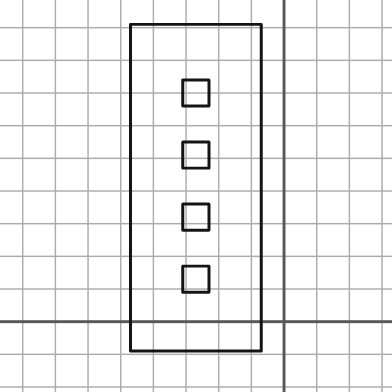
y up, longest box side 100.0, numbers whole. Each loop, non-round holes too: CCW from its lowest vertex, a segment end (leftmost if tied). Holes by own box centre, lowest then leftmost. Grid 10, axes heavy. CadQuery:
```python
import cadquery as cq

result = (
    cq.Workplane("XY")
    .moveTo(-47.0, -9.0)
    .lineTo(-7.0, -9.0)
    .lineTo(-7.0, 91.0)
    .lineTo(-47.0, 91.0)
    .close()
    .moveTo(-31.0, 9.0)
    .lineTo(-23.0, 9.0)
    .lineTo(-23.0, 17.0)
    .lineTo(-31.0, 17.0)
    .close()
    .moveTo(-31.0, 28.0)
    .lineTo(-23.0, 28.0)
    .lineTo(-23.0, 36.0)
    .lineTo(-31.0, 36.0)
    .close()
    .moveTo(-31.0, 47.0)
    .lineTo(-23.0, 47.0)
    .lineTo(-23.0, 55.0)
    .lineTo(-31.0, 55.0)
    .close()
    .moveTo(-31.0, 66.0)
    .lineTo(-23.0, 66.0)
    .lineTo(-23.0, 74.0)
    .lineTo(-31.0, 74.0)
    .close()
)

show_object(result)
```